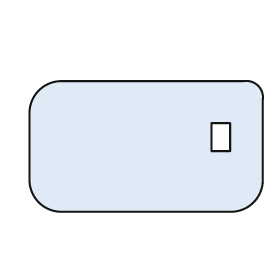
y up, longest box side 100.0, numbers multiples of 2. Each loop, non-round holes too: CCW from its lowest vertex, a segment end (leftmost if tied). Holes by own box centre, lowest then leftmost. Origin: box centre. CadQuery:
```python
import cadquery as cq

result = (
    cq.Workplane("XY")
    .moveTo(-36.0, -28.0)
    .lineTo(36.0, -28.0)
    .threePointArc((46.0, -24.0), (50.0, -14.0))
    .lineTo(50.0, 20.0)
    .threePointArc((48.0, 26.0), (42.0, 28.0))
    .lineTo(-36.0, 28.0)
    .threePointArc((-46.0, 24.0), (-50.0, 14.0))
    .lineTo(-50.0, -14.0)
    .threePointArc((-46.0, -24.0), (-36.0, -28.0))
    .close()
    .moveTo(28.0, -2.0)
    .lineTo(36.0, -2.0)
    .lineTo(36.0, 10.0)
    .lineTo(28.0, 10.0)
    .close()
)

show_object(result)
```